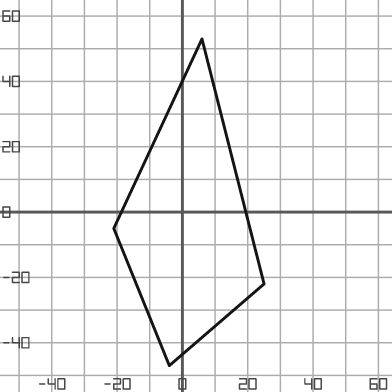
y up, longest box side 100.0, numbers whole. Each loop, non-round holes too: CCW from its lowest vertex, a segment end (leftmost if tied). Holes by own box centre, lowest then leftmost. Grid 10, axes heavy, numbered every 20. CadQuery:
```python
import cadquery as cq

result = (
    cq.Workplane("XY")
    .moveTo(-4.0, -47.0)
    .lineTo(25.0, -22.0)
    .lineTo(6.0, 53.0)
    .lineTo(-21.0, -5.0)
    .close()
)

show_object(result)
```